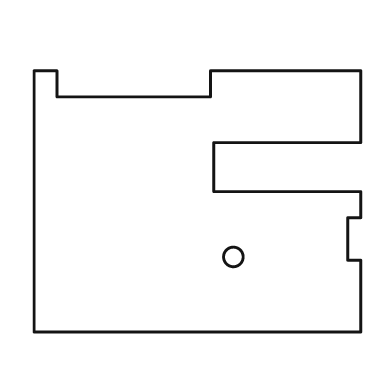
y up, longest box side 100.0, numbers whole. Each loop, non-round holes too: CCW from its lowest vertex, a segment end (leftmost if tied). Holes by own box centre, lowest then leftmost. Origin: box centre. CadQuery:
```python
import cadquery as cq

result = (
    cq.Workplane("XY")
    .moveTo(-50.0, -40.0)
    .lineTo(50.0, -40.0)
    .lineTo(50.0, -18.0)
    .lineTo(46.0, -18.0)
    .lineTo(46.0, -5.0)
    .lineTo(50.0, -5.0)
    .lineTo(50.0, 3.0)
    .lineTo(5.0, 3.0)
    .lineTo(5.0, 18.0)
    .lineTo(50.0, 18.0)
    .lineTo(50.0, 40.0)
    .lineTo(4.0, 40.0)
    .lineTo(4.0, 32.0)
    .lineTo(-43.0, 32.0)
    .lineTo(-43.0, 40.0)
    .lineTo(-50.0, 40.0)
    .close()
    .moveTo(11.0, -17.0)
    .circle(3.0)
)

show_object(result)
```